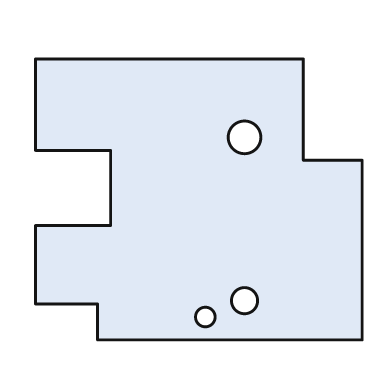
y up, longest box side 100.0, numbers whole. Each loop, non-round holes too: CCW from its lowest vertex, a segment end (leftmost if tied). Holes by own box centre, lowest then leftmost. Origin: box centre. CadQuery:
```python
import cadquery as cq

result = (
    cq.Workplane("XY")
    .moveTo(-31.0, -43.0)
    .lineTo(50.0, -43.0)
    .lineTo(50.0, 12.0)
    .lineTo(32.0, 12.0)
    .lineTo(32.0, 43.0)
    .lineTo(-50.0, 43.0)
    .lineTo(-50.0, 15.0)
    .lineTo(-27.0, 15.0)
    .lineTo(-27.0, -8.0)
    .lineTo(-50.0, -8.0)
    .lineTo(-50.0, -32.0)
    .lineTo(-31.0, -32.0)
    .close()
    .moveTo(2.0, -36.0)
    .circle(3.0)
    .moveTo(14.0, -31.0)
    .circle(4.0)
    .moveTo(14.0, 19.0)
    .circle(5.0)
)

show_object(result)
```